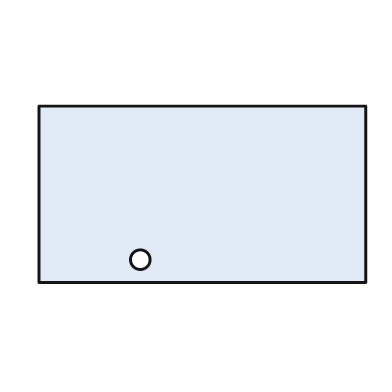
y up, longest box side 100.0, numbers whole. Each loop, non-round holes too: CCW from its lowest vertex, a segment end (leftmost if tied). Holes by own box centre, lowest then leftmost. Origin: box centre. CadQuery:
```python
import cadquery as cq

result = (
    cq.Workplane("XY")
    .moveTo(-50.0, -27.0)
    .lineTo(50.0, -27.0)
    .lineTo(50.0, 27.0)
    .lineTo(-50.0, 27.0)
    .close()
    .moveTo(-19.0, -20.0)
    .circle(3.0)
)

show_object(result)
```